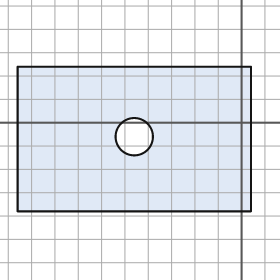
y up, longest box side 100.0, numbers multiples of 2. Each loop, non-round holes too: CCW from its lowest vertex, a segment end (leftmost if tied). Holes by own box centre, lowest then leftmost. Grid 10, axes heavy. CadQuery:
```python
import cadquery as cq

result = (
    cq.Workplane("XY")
    .moveTo(-96.0, -38.0)
    .lineTo(4.0, -38.0)
    .lineTo(4.0, 24.0)
    .lineTo(-96.0, 24.0)
    .close()
    .moveTo(-46.0, -6.0)
    .circle(8.0)
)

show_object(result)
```